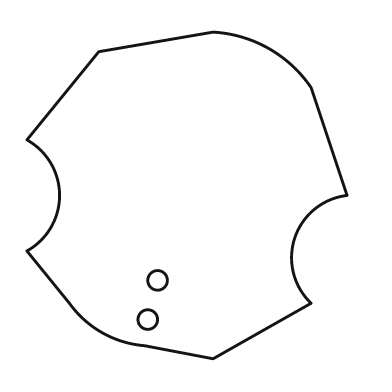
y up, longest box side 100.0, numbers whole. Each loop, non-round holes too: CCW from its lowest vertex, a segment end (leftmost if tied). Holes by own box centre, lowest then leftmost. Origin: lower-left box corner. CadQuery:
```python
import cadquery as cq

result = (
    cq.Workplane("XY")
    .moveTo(57.0, 0.0)
    .lineTo(87.0, 17.0)
    .threePointArc((82.0, 37.0), (98.0, 50.0))
    .lineTo(87.0, 83.0)
    .threePointArc((74.0, 95.0), (57.0, 100.0))
    .lineTo(22.0, 94.0)
    .lineTo(0.0, 67.0)
    .threePointArc((10.0, 50.0), (0.0, 33.0))
    .lineTo(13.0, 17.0)
    .threePointArc((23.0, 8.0), (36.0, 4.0))
    .close()
    .moveTo(37.0, 12.0)
    .circle(3.0)
    .moveTo(40.0, 24.0)
    .circle(3.0)
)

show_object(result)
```